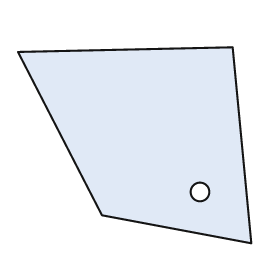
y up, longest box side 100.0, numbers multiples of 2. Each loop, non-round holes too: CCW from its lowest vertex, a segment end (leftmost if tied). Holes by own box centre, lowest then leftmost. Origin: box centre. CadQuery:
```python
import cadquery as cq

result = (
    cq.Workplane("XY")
    .moveTo(50.0, -42.0)
    .lineTo(42.0, 42.0)
    .lineTo(-50.0, 40.0)
    .lineTo(-14.0, -30.0)
    .close()
    .moveTo(28.0, -20.0)
    .circle(4.0)
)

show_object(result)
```